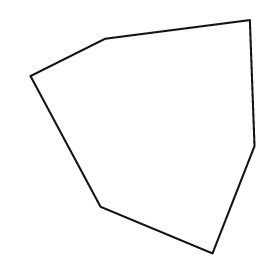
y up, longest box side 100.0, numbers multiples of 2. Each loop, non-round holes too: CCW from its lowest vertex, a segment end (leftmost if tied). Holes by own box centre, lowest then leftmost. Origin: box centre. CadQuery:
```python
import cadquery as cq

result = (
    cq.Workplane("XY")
    .moveTo(30.0, -50.0)
    .lineTo(48.0, -4.0)
    .lineTo(46.0, 50.0)
    .lineTo(-16.0, 42.0)
    .lineTo(-48.0, 26.0)
    .lineTo(-18.0, -30.0)
    .close()
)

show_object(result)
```